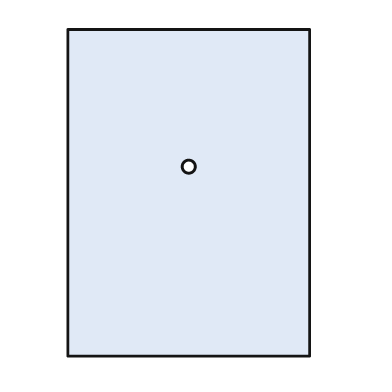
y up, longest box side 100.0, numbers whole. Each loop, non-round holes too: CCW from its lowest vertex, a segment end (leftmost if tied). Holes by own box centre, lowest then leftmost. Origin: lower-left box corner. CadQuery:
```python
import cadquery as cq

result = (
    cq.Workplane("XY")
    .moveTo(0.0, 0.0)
    .lineTo(74.0, 0.0)
    .lineTo(74.0, 100.0)
    .lineTo(0.0, 100.0)
    .close()
    .moveTo(37.0, 58.0)
    .circle(2.0)
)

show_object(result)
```